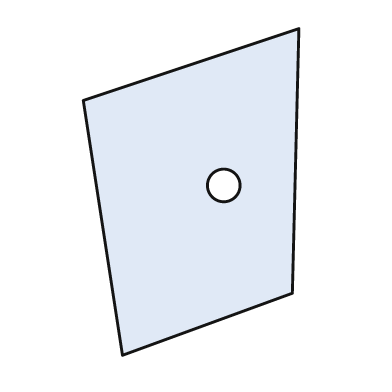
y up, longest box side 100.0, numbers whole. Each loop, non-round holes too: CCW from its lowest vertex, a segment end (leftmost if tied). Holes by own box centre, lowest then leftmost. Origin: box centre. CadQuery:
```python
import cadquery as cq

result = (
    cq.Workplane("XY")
    .moveTo(-21.0, -50.0)
    .lineTo(31.0, -31.0)
    .lineTo(33.0, 50.0)
    .lineTo(-33.0, 28.0)
    .close()
    .moveTo(10.0, 2.0)
    .circle(5.0)
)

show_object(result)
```